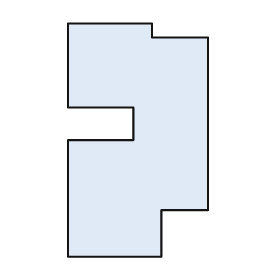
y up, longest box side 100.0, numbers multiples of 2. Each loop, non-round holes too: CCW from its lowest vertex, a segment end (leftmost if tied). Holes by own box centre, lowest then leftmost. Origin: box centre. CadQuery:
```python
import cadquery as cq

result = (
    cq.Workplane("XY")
    .moveTo(-30.0, -50.0)
    .lineTo(10.0, -50.0)
    .lineTo(10.0, -30.0)
    .lineTo(30.0, -30.0)
    .lineTo(30.0, 44.0)
    .lineTo(6.0, 44.0)
    .lineTo(6.0, 50.0)
    .lineTo(-30.0, 50.0)
    .lineTo(-30.0, 14.0)
    .lineTo(-2.0, 14.0)
    .lineTo(-2.0, 0.0)
    .lineTo(-30.0, 0.0)
    .close()
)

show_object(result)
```